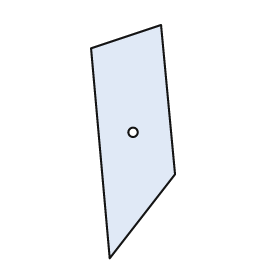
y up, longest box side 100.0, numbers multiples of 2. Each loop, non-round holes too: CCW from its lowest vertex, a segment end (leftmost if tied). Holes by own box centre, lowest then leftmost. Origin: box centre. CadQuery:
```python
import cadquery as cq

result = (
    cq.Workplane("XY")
    .moveTo(-10.0, -50.0)
    .lineTo(18.0, -14.0)
    .lineTo(12.0, 50.0)
    .lineTo(-18.0, 40.0)
    .close()
    .moveTo(0.0, 4.0)
    .circle(2.0)
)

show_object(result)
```